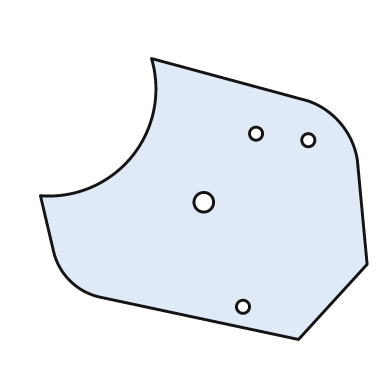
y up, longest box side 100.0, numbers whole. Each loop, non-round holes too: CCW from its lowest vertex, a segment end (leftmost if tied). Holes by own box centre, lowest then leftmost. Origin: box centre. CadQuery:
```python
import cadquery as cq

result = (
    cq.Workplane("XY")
    .moveTo(29.0, -43.0)
    .lineTo(50.0, -20.0)
    .lineTo(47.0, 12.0)
    .threePointArc((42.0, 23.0), (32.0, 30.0))
    .lineTo(-16.0, 43.0)
    .threePointArc((-22.0, 13.0), (-50.0, 1.0))
    .lineTo(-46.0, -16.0)
    .threePointArc((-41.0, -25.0), (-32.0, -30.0))
    .close()
    .moveTo(12.0, -33.0)
    .circle(2.0)
    .moveTo(0.0, -1.0)
    .circle(3.0)
    .moveTo(32.0, 18.0)
    .circle(2.0)
    .moveTo(16.0, 20.0)
    .circle(2.0)
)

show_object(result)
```